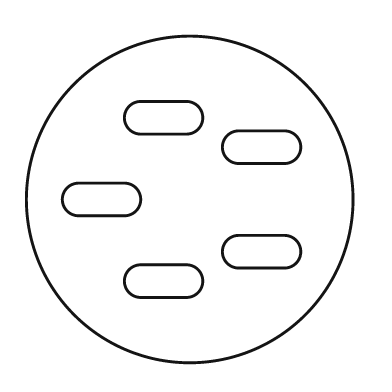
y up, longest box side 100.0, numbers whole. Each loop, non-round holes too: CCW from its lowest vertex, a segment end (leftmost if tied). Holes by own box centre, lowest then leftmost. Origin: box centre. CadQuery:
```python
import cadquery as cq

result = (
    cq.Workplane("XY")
    .moveTo(0.0, 0.0)
    .circle(50.0)
    .moveTo(-15.0, -30.0)
    .lineTo(-1.0, -30.0)
    .threePointArc((4.0, -25.0), (-1.0, -20.0))
    .lineTo(-15.0, -20.0)
    .threePointArc((-20.0, -25.0), (-15.0, -30.0))
    .close()
    .moveTo(15.0, -21.0)
    .lineTo(29.0, -21.0)
    .threePointArc((34.0, -16.0), (29.0, -11.0))
    .lineTo(15.0, -11.0)
    .threePointArc((10.0, -16.0), (15.0, -21.0))
    .close()
    .moveTo(-34.0, -5.0)
    .lineTo(-20.0, -5.0)
    .threePointArc((-15.0, 0.0), (-20.0, 5.0))
    .lineTo(-34.0, 5.0)
    .threePointArc((-39.0, 0.0), (-34.0, -5.0))
    .close()
    .moveTo(15.0, 11.0)
    .lineTo(29.0, 11.0)
    .threePointArc((34.0, 16.0), (29.0, 21.0))
    .lineTo(15.0, 21.0)
    .threePointArc((10.0, 16.0), (15.0, 11.0))
    .close()
    .moveTo(-15.0, 20.0)
    .lineTo(-1.0, 20.0)
    .threePointArc((4.0, 25.0), (-1.0, 30.0))
    .lineTo(-15.0, 30.0)
    .threePointArc((-20.0, 25.0), (-15.0, 20.0))
    .close()
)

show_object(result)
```